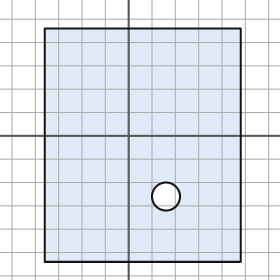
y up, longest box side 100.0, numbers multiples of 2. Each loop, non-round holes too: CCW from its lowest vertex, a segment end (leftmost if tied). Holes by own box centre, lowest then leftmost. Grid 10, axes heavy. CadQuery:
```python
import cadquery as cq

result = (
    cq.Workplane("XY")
    .moveTo(-36.0, -54.0)
    .lineTo(48.0, -54.0)
    .lineTo(48.0, 46.0)
    .lineTo(-36.0, 46.0)
    .close()
    .moveTo(16.0, -26.0)
    .circle(6.0)
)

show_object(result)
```